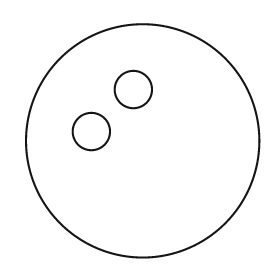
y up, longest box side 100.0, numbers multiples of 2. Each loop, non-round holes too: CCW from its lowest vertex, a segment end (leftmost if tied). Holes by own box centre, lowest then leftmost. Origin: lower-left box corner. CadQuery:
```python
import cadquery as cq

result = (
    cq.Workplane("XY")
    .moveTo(50.0, 50.0)
    .circle(50.0)
    .moveTo(28.0, 54.0)
    .circle(8.0)
    .moveTo(46.0, 72.0)
    .circle(8.0)
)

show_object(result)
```